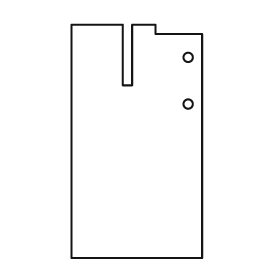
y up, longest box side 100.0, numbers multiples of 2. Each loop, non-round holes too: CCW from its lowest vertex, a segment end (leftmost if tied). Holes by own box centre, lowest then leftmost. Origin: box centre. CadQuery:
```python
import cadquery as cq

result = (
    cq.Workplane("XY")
    .moveTo(-28.0, -50.0)
    .lineTo(28.0, -50.0)
    .lineTo(28.0, 46.0)
    .lineTo(8.0, 46.0)
    .lineTo(8.0, 50.0)
    .lineTo(-2.0, 50.0)
    .lineTo(-2.0, 24.0)
    .lineTo(-6.0, 24.0)
    .lineTo(-6.0, 50.0)
    .lineTo(-28.0, 50.0)
    .close()
    .moveTo(22.0, 16.0)
    .circle(2.0)
    .moveTo(22.0, 36.0)
    .circle(2.0)
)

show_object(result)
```